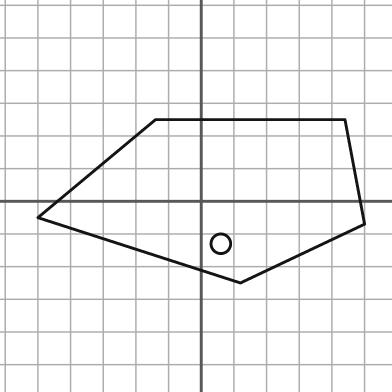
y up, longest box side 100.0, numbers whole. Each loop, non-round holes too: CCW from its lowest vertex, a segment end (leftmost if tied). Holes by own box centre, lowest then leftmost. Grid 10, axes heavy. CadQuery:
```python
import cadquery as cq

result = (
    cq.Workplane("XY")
    .moveTo(12.0, -25.0)
    .lineTo(50.0, -7.0)
    .lineTo(44.0, 25.0)
    .lineTo(-14.0, 25.0)
    .lineTo(-50.0, -5.0)
    .close()
    .moveTo(6.0, -13.0)
    .circle(3.0)
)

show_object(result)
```